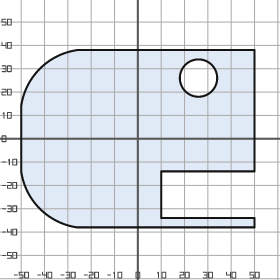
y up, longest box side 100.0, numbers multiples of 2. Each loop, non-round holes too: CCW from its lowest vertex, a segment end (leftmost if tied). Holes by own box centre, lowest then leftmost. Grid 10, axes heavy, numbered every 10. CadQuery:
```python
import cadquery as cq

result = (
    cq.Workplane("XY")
    .moveTo(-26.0, -38.0)
    .lineTo(50.0, -38.0)
    .lineTo(50.0, -34.0)
    .lineTo(10.0, -34.0)
    .lineTo(10.0, -14.0)
    .lineTo(50.0, -14.0)
    .lineTo(50.0, 38.0)
    .lineTo(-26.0, 38.0)
    .threePointArc((-42.0, 30.0), (-50.0, 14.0))
    .lineTo(-50.0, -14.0)
    .threePointArc((-42.0, -30.0), (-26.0, -38.0))
    .close()
    .moveTo(26.0, 26.0)
    .circle(8.0)
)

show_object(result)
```